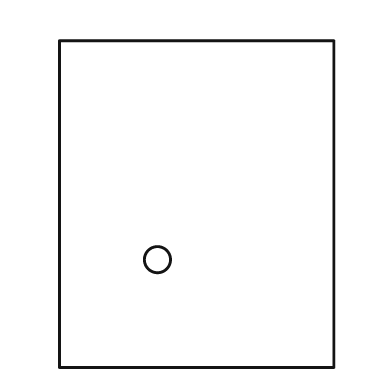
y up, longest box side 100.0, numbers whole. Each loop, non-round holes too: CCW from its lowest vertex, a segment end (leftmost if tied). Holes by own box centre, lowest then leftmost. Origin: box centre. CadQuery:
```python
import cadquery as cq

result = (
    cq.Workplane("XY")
    .moveTo(-42.0, -50.0)
    .lineTo(42.0, -50.0)
    .lineTo(42.0, 50.0)
    .lineTo(-42.0, 50.0)
    .close()
    .moveTo(-12.0, -17.0)
    .circle(4.0)
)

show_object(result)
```